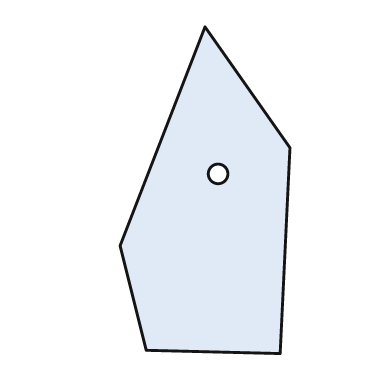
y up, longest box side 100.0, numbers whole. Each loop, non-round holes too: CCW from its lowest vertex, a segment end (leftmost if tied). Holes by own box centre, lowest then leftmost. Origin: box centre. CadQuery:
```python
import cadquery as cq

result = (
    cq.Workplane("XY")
    .moveTo(23.0, -50.0)
    .lineTo(26.0, 13.0)
    .lineTo(0.0, 50.0)
    .lineTo(-26.0, -17.0)
    .lineTo(-18.0, -49.0)
    .close()
    .moveTo(4.0, 5.0)
    .circle(3.0)
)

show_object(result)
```